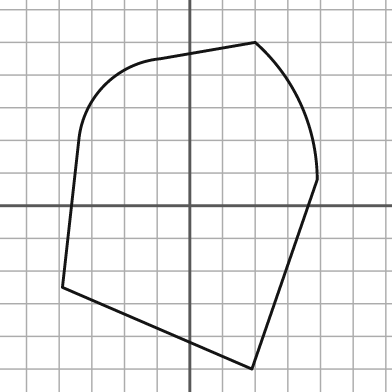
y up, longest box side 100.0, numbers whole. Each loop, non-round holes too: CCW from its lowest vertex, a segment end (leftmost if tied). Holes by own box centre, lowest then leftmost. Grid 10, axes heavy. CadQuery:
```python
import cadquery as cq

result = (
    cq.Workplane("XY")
    .moveTo(19.0, -50.0)
    .lineTo(39.0, 8.0)
    .threePointArc((34.0, 31.0), (20.0, 50.0))
    .lineTo(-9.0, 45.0)
    .threePointArc((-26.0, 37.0), (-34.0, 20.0))
    .lineTo(-39.0, -25.0)
    .close()
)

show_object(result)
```